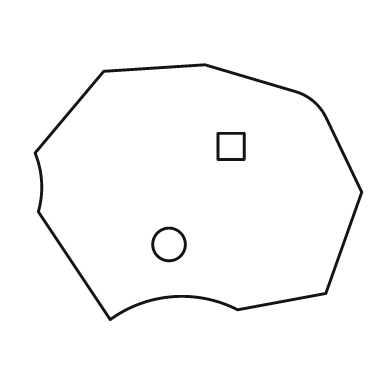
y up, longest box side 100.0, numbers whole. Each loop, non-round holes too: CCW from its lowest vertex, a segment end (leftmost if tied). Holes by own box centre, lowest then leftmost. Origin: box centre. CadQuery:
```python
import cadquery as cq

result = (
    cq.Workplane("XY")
    .moveTo(-27.0, -39.0)
    .threePointArc((-8.0, -32.0), (12.0, -36.0))
    .lineTo(39.0, -31.0)
    .lineTo(50.0, 0.0)
    .lineTo(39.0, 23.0)
    .threePointArc((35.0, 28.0), (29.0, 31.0))
    .lineTo(2.0, 39.0)
    .lineTo(-29.0, 37.0)
    .lineTo(-50.0, 12.0)
    .threePointArc((-48.0, 3.0), (-49.0, -6.0))
    .close()
    .moveTo(-9.0, -16.0)
    .circle(5.0)
    .moveTo(6.0, 10.0)
    .lineTo(14.0, 10.0)
    .lineTo(14.0, 18.0)
    .lineTo(6.0, 18.0)
    .close()
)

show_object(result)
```